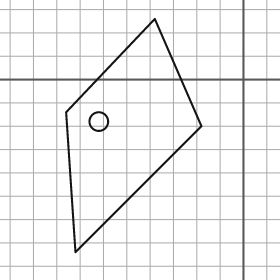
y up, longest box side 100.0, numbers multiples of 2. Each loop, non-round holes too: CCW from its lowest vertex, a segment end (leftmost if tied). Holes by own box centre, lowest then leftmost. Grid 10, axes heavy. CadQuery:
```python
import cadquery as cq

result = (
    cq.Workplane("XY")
    .moveTo(-72.0, -74.0)
    .lineTo(-18.0, -20.0)
    .lineTo(-38.0, 26.0)
    .lineTo(-76.0, -14.0)
    .close()
    .moveTo(-62.0, -18.0)
    .circle(4.0)
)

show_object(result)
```